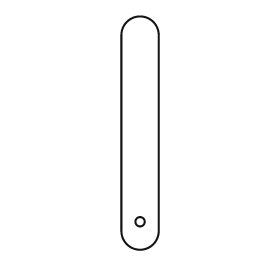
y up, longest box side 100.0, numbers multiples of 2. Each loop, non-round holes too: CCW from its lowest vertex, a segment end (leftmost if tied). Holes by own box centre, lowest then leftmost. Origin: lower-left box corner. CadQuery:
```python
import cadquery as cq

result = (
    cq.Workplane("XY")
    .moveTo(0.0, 8.0)
    .threePointArc((8.0, 0.0), (16.0, 8.0))
    .lineTo(16.0, 92.0)
    .threePointArc((8.0, 100.0), (0.0, 92.0))
    .close()
    .moveTo(8.0, 12.0)
    .circle(2.0)
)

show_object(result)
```